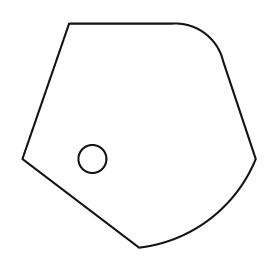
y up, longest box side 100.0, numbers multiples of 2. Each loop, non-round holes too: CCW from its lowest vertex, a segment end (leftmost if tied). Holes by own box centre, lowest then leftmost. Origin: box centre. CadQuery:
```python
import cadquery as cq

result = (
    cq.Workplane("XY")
    .moveTo(0.0, -48.0)
    .threePointArc((30.0, -36.0), (50.0, -10.0))
    .lineTo(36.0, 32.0)
    .threePointArc((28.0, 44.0), (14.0, 48.0))
    .lineTo(-30.0, 48.0)
    .lineTo(-50.0, -10.0)
    .close()
    .moveTo(-20.0, -10.0)
    .circle(6.0)
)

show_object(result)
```